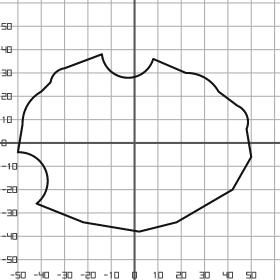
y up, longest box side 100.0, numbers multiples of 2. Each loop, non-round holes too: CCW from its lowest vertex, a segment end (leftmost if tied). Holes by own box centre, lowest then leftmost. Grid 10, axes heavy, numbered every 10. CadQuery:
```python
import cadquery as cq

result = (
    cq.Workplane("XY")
    .moveTo(2.0, -38.0)
    .lineTo(18.0, -34.0)
    .lineTo(42.0, -20.0)
    .lineTo(50.0, -6.0)
    .lineTo(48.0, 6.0)
    .threePointArc((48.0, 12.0), (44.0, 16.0))
    .lineTo(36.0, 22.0)
    .threePointArc((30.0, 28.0), (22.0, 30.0))
    .lineTo(8.0, 36.0)
    .threePointArc((-4.0, 28.0), (-14.0, 38.0))
    .lineTo(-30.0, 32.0)
    .threePointArc((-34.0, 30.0), (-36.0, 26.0))
    .lineTo(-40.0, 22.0)
    .threePointArc((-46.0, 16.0), (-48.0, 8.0))
    .lineTo(-50.0, -4.0)
    .threePointArc((-38.0, -12.0), (-42.0, -26.0))
    .lineTo(-22.0, -34.0)
    .close()
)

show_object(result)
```